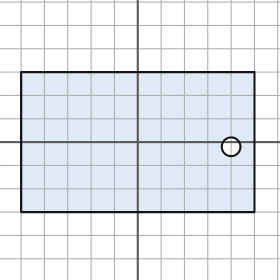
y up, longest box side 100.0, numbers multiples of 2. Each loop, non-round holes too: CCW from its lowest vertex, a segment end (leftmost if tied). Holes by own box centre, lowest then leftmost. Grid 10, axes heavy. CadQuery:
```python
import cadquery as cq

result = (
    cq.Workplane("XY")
    .moveTo(-50.0, -30.0)
    .lineTo(50.0, -30.0)
    .lineTo(50.0, 30.0)
    .lineTo(-50.0, 30.0)
    .close()
    .moveTo(40.0, -2.0)
    .circle(4.0)
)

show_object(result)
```